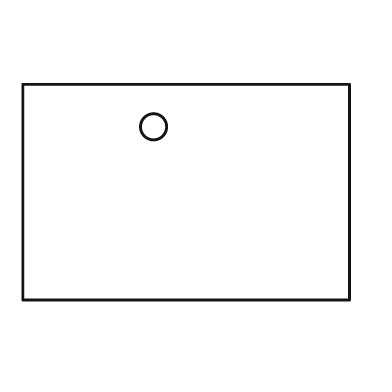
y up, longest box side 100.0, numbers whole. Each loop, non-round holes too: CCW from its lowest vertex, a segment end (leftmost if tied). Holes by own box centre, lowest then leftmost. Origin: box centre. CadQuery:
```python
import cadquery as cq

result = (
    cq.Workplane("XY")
    .moveTo(-50.0, -33.0)
    .lineTo(50.0, -33.0)
    .lineTo(50.0, 33.0)
    .lineTo(-50.0, 33.0)
    .close()
    .moveTo(-10.0, 20.0)
    .circle(4.0)
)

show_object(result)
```